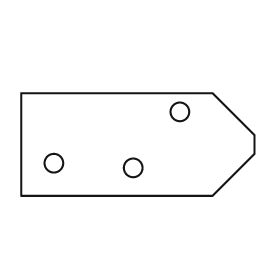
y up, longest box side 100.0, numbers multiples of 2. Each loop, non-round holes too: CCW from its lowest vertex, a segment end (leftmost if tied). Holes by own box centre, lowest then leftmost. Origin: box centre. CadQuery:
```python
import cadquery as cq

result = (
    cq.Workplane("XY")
    .moveTo(-50.0, -22.0)
    .lineTo(32.0, -22.0)
    .lineTo(50.0, -4.0)
    .lineTo(50.0, 4.0)
    .lineTo(32.0, 22.0)
    .lineTo(-50.0, 22.0)
    .close()
    .moveTo(-2.0, -10.0)
    .circle(4.0)
    .moveTo(-36.0, -8.0)
    .circle(4.0)
    .moveTo(18.0, 14.0)
    .circle(4.0)
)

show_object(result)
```